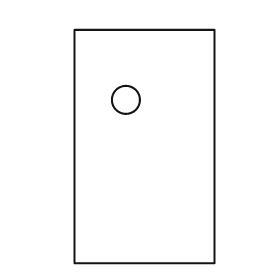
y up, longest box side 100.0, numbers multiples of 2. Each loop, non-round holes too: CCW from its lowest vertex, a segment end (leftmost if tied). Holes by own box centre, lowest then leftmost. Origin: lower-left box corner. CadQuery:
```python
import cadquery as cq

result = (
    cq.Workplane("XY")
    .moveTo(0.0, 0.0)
    .lineTo(60.0, 0.0)
    .lineTo(60.0, 100.0)
    .lineTo(0.0, 100.0)
    .close()
    .moveTo(22.0, 70.0)
    .circle(6.0)
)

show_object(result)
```